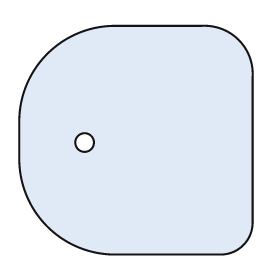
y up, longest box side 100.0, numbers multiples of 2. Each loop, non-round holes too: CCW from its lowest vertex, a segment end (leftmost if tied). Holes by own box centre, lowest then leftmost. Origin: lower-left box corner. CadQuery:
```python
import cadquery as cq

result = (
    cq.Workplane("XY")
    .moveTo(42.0, 0.0)
    .lineTo(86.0, 0.0)
    .threePointArc((96.0, 4.0), (100.0, 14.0))
    .lineTo(100.0, 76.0)
    .threePointArc((94.0, 92.0), (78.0, 98.0))
    .lineTo(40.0, 98.0)
    .threePointArc((12.0, 86.0), (0.0, 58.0))
    .lineTo(0.0, 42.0)
    .threePointArc((12.0, 12.0), (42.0, 0.0))
    .close()
    .moveTo(28.0, 48.0)
    .circle(4.0)
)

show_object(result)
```